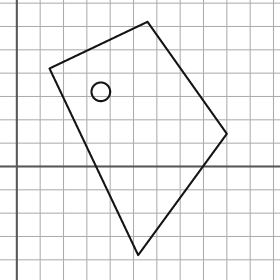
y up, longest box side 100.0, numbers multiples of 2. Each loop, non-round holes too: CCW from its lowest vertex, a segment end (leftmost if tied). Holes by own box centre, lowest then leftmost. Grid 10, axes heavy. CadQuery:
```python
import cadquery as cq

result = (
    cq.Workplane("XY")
    .moveTo(52.0, -38.0)
    .lineTo(90.0, 14.0)
    .lineTo(56.0, 62.0)
    .lineTo(14.0, 42.0)
    .close()
    .moveTo(36.0, 32.0)
    .circle(4.0)
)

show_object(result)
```